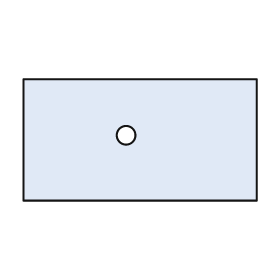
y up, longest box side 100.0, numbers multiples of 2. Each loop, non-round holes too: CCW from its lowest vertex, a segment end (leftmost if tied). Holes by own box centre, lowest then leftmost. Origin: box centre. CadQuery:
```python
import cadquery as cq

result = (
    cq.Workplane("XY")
    .moveTo(-50.0, -26.0)
    .lineTo(50.0, -26.0)
    .lineTo(50.0, 26.0)
    .lineTo(-50.0, 26.0)
    .close()
    .moveTo(-6.0, 2.0)
    .circle(4.0)
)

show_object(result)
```